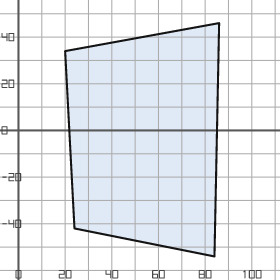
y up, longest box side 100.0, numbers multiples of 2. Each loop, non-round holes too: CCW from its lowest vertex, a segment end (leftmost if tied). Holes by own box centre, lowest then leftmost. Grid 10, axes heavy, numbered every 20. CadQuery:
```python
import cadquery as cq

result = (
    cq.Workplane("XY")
    .moveTo(84.0, -54.0)
    .lineTo(86.0, 46.0)
    .lineTo(20.0, 34.0)
    .lineTo(24.0, -42.0)
    .close()
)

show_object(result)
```